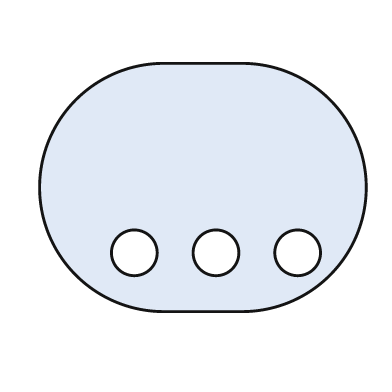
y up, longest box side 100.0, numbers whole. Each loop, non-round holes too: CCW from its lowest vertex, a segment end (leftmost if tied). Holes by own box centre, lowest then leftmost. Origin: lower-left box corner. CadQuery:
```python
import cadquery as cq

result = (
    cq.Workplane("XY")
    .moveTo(38.0, 0.0)
    .lineTo(62.0, 0.0)
    .threePointArc((100.0, 38.0), (62.0, 76.0))
    .lineTo(38.0, 76.0)
    .threePointArc((0.0, 38.0), (38.0, 0.0))
    .close()
    .moveTo(29.0, 18.0)
    .circle(7.0)
    .moveTo(54.0, 18.0)
    .circle(7.0)
    .moveTo(79.0, 18.0)
    .circle(7.0)
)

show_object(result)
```